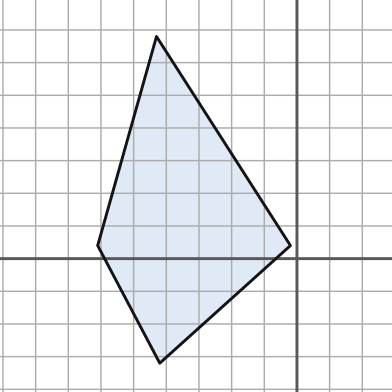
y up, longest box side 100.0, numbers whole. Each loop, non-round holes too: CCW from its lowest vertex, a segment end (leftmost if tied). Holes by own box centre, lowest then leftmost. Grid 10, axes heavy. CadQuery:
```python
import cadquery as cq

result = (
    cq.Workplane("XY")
    .moveTo(-42.0, -32.0)
    .lineTo(-2.0, 4.0)
    .lineTo(-43.0, 68.0)
    .lineTo(-61.0, 4.0)
    .close()
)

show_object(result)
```